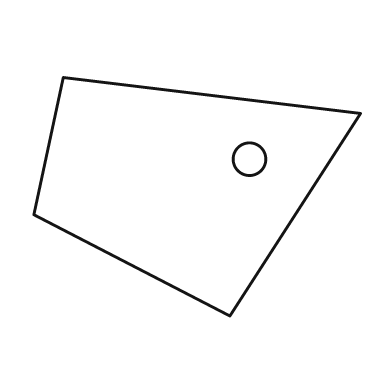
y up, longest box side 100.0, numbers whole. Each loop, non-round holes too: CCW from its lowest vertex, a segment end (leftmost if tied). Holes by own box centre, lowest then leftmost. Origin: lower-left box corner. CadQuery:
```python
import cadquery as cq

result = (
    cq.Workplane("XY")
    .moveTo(60.0, 0.0)
    .lineTo(100.0, 62.0)
    .lineTo(9.0, 73.0)
    .lineTo(0.0, 31.0)
    .close()
    .moveTo(66.0, 48.0)
    .circle(5.0)
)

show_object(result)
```